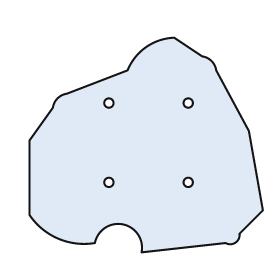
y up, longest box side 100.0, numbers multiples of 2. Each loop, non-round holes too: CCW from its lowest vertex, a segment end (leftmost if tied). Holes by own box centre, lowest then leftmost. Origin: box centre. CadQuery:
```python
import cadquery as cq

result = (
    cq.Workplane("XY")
    .moveTo(-2.0, -46.0)
    .lineTo(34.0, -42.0)
    .threePointArc((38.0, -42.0), (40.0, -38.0))
    .lineTo(50.0, -28.0)
    .lineTo(44.0, 6.0)
    .lineTo(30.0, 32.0)
    .threePointArc((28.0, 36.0), (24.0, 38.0))
    .lineTo(12.0, 46.0)
    .threePointArc((0.0, 42.0), (-8.0, 32.0))
    .lineTo(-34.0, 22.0)
    .threePointArc((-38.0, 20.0), (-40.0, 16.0))
    .lineTo(-50.0, 2.0)
    .lineTo(-50.0, -30.0)
    .threePointArc((-38.0, -40.0), (-22.0, -42.0))
    .threePointArc((-10.0, -34.0), (-2.0, -46.0))
    .close()
    .moveTo(-16.0, -16.0)
    .circle(2.0)
    .moveTo(18.0, -16.0)
    .circle(2.0)
    .moveTo(-16.0, 18.0)
    .circle(2.0)
    .moveTo(18.0, 18.0)
    .circle(2.0)
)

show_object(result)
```